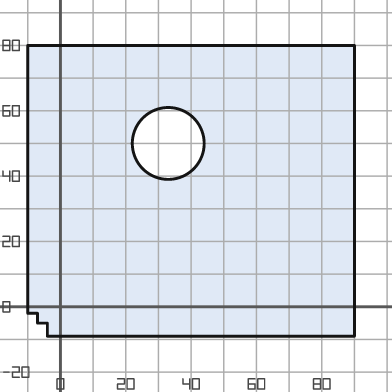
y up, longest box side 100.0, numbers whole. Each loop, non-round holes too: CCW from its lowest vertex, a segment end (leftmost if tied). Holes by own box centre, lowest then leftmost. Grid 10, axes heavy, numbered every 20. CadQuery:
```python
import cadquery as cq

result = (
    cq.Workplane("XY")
    .moveTo(-4.0, -9.0)
    .lineTo(90.0, -9.0)
    .lineTo(90.0, 80.0)
    .lineTo(-10.0, 80.0)
    .lineTo(-10.0, -2.0)
    .lineTo(-7.0, -2.0)
    .lineTo(-7.0, -5.0)
    .lineTo(-4.0, -5.0)
    .close()
    .moveTo(33.0, 50.0)
    .circle(11.0)
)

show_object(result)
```